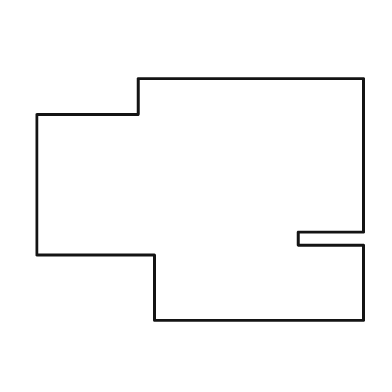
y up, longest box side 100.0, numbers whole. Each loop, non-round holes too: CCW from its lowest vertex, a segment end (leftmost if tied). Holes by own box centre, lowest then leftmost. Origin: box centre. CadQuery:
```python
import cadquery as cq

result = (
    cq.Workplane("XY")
    .moveTo(-14.0, -37.0)
    .lineTo(50.0, -37.0)
    .lineTo(50.0, -14.0)
    .lineTo(30.0, -14.0)
    .lineTo(30.0, -10.0)
    .lineTo(50.0, -10.0)
    .lineTo(50.0, 37.0)
    .lineTo(-19.0, 37.0)
    .lineTo(-19.0, 26.0)
    .lineTo(-50.0, 26.0)
    .lineTo(-50.0, -17.0)
    .lineTo(-14.0, -17.0)
    .close()
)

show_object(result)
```